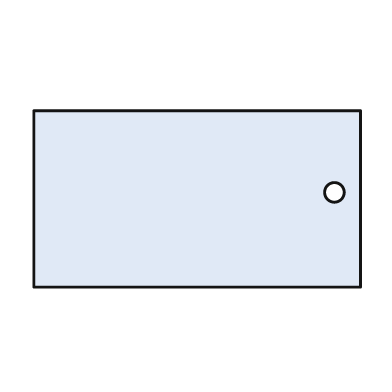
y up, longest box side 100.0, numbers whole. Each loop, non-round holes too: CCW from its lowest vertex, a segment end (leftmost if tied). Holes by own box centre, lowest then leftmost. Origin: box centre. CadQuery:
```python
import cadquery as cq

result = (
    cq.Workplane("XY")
    .moveTo(-50.0, -27.0)
    .lineTo(50.0, -27.0)
    .lineTo(50.0, 27.0)
    .lineTo(-50.0, 27.0)
    .close()
    .moveTo(42.0, 2.0)
    .circle(3.0)
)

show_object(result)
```